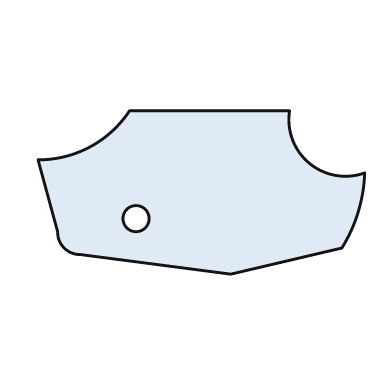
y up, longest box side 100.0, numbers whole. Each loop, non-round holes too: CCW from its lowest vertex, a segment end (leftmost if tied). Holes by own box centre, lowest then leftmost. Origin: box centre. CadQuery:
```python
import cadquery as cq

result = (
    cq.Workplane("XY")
    .moveTo(9.0, -25.0)
    .lineTo(43.0, -17.0)
    .threePointArc((48.0, -6.0), (50.0, 6.0))
    .threePointArc((33.0, 9.0), (27.0, 25.0))
    .lineTo(-22.0, 25.0)
    .threePointArc((-34.0, 14.0), (-50.0, 10.0))
    .lineTo(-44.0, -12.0)
    .threePointArc((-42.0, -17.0), (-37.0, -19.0))
    .close()
    .moveTo(-20.0, -8.0)
    .circle(4.0)
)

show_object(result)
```